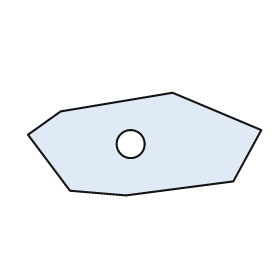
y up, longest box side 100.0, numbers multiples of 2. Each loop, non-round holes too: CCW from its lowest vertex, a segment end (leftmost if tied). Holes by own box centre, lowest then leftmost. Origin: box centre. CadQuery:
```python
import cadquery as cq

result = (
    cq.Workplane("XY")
    .moveTo(-8.0, -22.0)
    .lineTo(38.0, -16.0)
    .lineTo(50.0, 6.0)
    .lineTo(12.0, 22.0)
    .lineTo(-36.0, 14.0)
    .lineTo(-50.0, 4.0)
    .lineTo(-32.0, -20.0)
    .close()
    .moveTo(-6.0, 0.0)
    .circle(6.0)
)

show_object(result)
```